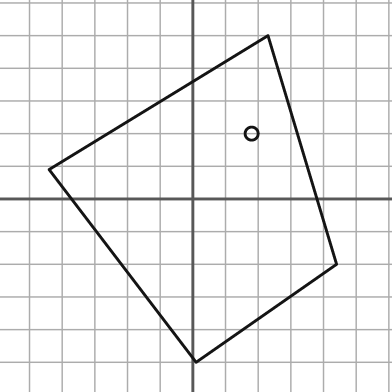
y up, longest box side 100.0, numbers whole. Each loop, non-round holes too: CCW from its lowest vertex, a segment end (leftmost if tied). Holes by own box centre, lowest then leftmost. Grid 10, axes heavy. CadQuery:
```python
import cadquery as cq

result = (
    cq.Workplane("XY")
    .moveTo(1.0, -50.0)
    .lineTo(44.0, -20.0)
    .lineTo(23.0, 50.0)
    .lineTo(-44.0, 9.0)
    .close()
    .moveTo(18.0, 20.0)
    .circle(2.0)
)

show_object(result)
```